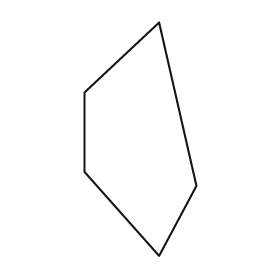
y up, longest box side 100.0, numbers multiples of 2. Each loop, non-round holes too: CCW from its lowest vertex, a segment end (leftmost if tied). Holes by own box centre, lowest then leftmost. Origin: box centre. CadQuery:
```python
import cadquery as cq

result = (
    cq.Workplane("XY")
    .moveTo(8.0, -50.0)
    .lineTo(24.0, -20.0)
    .lineTo(8.0, 50.0)
    .lineTo(-24.0, 20.0)
    .lineTo(-24.0, -14.0)
    .close()
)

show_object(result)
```